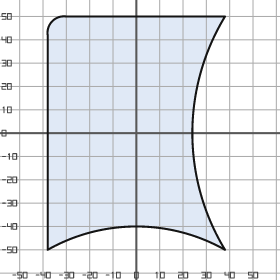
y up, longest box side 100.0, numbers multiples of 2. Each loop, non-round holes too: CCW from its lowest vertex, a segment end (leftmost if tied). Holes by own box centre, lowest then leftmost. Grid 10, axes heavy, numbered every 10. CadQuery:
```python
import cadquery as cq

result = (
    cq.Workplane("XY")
    .moveTo(-38.0, -50.0)
    .threePointArc((0.0, -40.0), (38.0, -50.0))
    .threePointArc((24.0, 0.0), (38.0, 50.0))
    .lineTo(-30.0, 50.0)
    .threePointArc((-36.0, 48.0), (-38.0, 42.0))
    .close()
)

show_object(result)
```